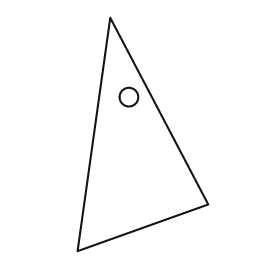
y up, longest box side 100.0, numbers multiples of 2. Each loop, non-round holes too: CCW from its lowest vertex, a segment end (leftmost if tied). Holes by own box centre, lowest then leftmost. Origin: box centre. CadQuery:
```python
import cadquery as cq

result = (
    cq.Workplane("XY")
    .moveTo(-28.0, -50.0)
    .lineTo(28.0, -30.0)
    .lineTo(-14.0, 50.0)
    .close()
    .moveTo(-6.0, 16.0)
    .circle(4.0)
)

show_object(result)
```